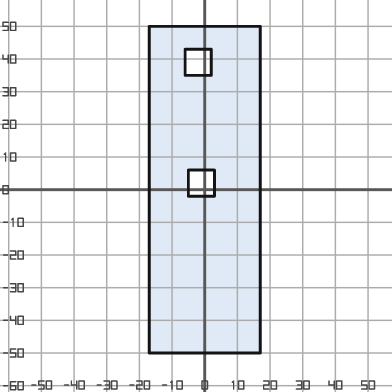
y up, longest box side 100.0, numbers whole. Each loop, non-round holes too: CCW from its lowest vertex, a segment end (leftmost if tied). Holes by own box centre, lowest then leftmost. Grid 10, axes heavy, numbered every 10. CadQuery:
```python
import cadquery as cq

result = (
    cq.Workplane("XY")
    .moveTo(-17.0, -50.0)
    .lineTo(17.0, -50.0)
    .lineTo(17.0, 50.0)
    .lineTo(-17.0, 50.0)
    .close()
    .moveTo(-5.0, -2.0)
    .lineTo(3.0, -2.0)
    .lineTo(3.0, 6.0)
    .lineTo(-5.0, 6.0)
    .close()
    .moveTo(-6.0, 35.0)
    .lineTo(2.0, 35.0)
    .lineTo(2.0, 43.0)
    .lineTo(-6.0, 43.0)
    .close()
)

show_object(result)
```